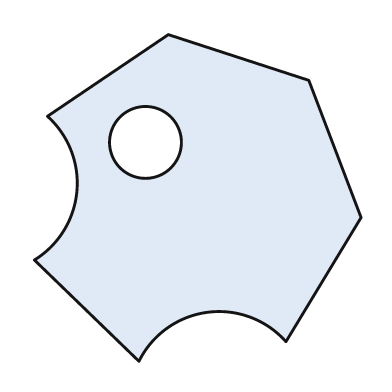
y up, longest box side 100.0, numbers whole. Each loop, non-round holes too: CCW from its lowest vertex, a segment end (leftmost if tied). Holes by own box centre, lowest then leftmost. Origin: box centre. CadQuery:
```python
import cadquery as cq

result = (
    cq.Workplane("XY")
    .moveTo(-18.0, -50.0)
    .threePointArc((3.0, -35.0), (27.0, -44.0))
    .lineTo(50.0, -6.0)
    .lineTo(34.0, 36.0)
    .lineTo(-9.0, 50.0)
    .lineTo(-46.0, 25.0)
    .threePointArc((-37.0, 2.0), (-50.0, -19.0))
    .close()
    .moveTo(-16.0, 17.0)
    .circle(11.0)
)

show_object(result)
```